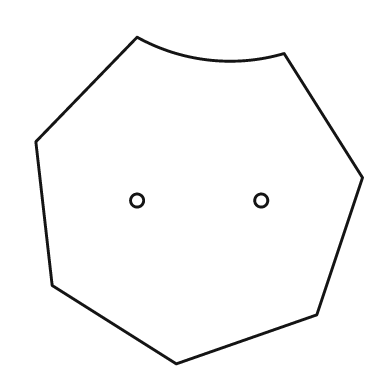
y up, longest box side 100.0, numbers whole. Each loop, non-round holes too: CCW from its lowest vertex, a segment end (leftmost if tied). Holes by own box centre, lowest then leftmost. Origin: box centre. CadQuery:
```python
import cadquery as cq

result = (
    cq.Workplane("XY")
    .moveTo(-7.0, -50.0)
    .lineTo(36.0, -35.0)
    .lineTo(50.0, 7.0)
    .lineTo(26.0, 45.0)
    .threePointArc((3.0, 43.0), (-19.0, 50.0))
    .lineTo(-50.0, 18.0)
    .lineTo(-45.0, -26.0)
    .close()
    .moveTo(-19.0, 0.0)
    .circle(2.0)
    .moveTo(19.0, 0.0)
    .circle(2.0)
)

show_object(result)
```